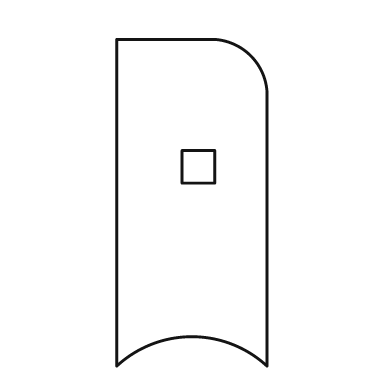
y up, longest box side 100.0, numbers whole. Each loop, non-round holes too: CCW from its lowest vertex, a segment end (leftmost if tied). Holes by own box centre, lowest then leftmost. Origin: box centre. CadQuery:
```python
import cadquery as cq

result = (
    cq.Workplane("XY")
    .moveTo(-23.0, -50.0)
    .threePointArc((0.0, -41.0), (23.0, -50.0))
    .lineTo(23.0, 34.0)
    .threePointArc((18.0, 45.0), (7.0, 50.0))
    .lineTo(-23.0, 50.0)
    .close()
    .moveTo(-3.0, 6.0)
    .lineTo(7.0, 6.0)
    .lineTo(7.0, 16.0)
    .lineTo(-3.0, 16.0)
    .close()
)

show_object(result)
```